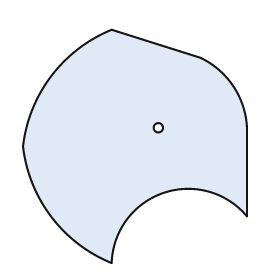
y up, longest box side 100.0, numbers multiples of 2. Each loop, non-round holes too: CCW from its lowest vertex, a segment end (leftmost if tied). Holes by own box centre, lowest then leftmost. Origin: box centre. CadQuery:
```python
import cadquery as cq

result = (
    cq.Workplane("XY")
    .moveTo(-10.0, -50.0)
    .threePointArc((12.0, -20.0), (48.0, -30.0))
    .lineTo(48.0, 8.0)
    .threePointArc((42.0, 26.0), (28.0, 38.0))
    .lineTo(-10.0, 50.0)
    .threePointArc((-36.0, 30.0), (-48.0, 0.0))
    .threePointArc((-36.0, -30.0), (-10.0, -50.0))
    .close()
    .moveTo(10.0, 8.0)
    .circle(2.0)
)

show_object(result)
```